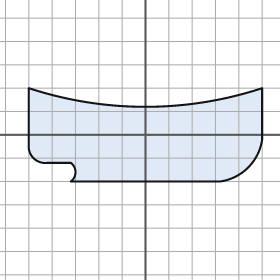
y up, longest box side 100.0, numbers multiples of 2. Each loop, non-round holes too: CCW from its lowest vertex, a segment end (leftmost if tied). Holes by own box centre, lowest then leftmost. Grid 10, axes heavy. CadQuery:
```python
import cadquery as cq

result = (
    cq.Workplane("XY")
    .moveTo(-32.0, -20.0)
    .lineTo(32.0, -20.0)
    .threePointArc((44.0, -14.0), (50.0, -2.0))
    .lineTo(50.0, 20.0)
    .threePointArc((0.0, 12.0), (-50.0, 20.0))
    .lineTo(-50.0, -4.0)
    .threePointArc((-48.0, -10.0), (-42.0, -12.0))
    .lineTo(-32.0, -12.0)
    .threePointArc((-30.0, -16.0), (-32.0, -20.0))
    .close()
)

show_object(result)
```